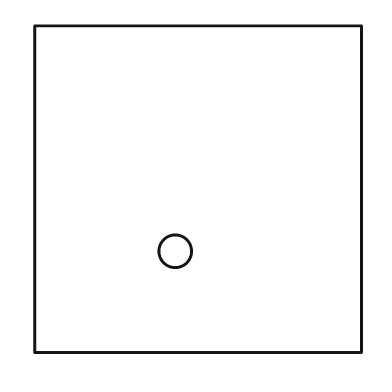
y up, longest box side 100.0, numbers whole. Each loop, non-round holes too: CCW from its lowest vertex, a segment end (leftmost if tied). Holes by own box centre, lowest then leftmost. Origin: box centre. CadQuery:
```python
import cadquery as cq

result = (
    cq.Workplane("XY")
    .moveTo(-50.0, -50.0)
    .lineTo(50.0, -50.0)
    .lineTo(50.0, 50.0)
    .lineTo(-50.0, 50.0)
    .close()
    .moveTo(-7.0, -19.0)
    .circle(5.0)
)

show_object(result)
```